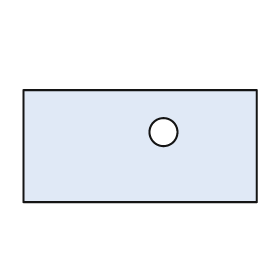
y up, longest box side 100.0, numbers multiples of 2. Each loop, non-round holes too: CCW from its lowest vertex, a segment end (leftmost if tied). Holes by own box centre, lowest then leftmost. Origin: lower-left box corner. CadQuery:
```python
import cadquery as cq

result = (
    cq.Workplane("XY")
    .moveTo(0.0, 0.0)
    .lineTo(100.0, 0.0)
    .lineTo(100.0, 48.0)
    .lineTo(0.0, 48.0)
    .close()
    .moveTo(60.0, 30.0)
    .circle(6.0)
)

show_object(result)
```